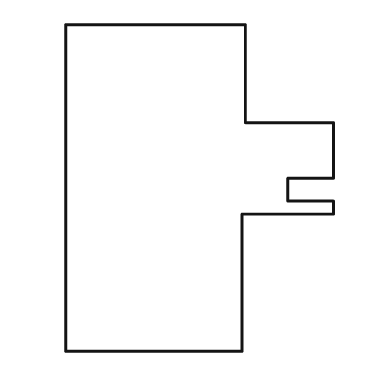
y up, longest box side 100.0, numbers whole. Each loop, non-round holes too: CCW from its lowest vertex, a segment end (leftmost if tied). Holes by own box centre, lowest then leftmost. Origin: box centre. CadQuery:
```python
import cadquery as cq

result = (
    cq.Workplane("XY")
    .moveTo(-41.0, -50.0)
    .lineTo(13.0, -50.0)
    .lineTo(13.0, -8.0)
    .lineTo(41.0, -8.0)
    .lineTo(41.0, -4.0)
    .lineTo(27.0, -4.0)
    .lineTo(27.0, 3.0)
    .lineTo(41.0, 3.0)
    .lineTo(41.0, 20.0)
    .lineTo(14.0, 20.0)
    .lineTo(14.0, 50.0)
    .lineTo(-41.0, 50.0)
    .close()
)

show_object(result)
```